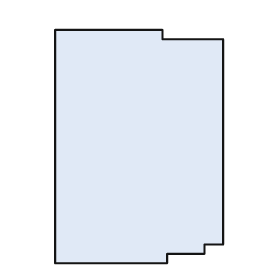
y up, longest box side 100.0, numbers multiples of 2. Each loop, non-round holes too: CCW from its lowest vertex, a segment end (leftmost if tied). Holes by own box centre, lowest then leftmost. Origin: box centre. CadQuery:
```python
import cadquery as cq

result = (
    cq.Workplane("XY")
    .moveTo(-36.0, -50.0)
    .lineTo(12.0, -50.0)
    .lineTo(12.0, -46.0)
    .lineTo(28.0, -46.0)
    .lineTo(28.0, -42.0)
    .lineTo(36.0, -42.0)
    .lineTo(36.0, 46.0)
    .lineTo(10.0, 46.0)
    .lineTo(10.0, 50.0)
    .lineTo(-36.0, 50.0)
    .close()
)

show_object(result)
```